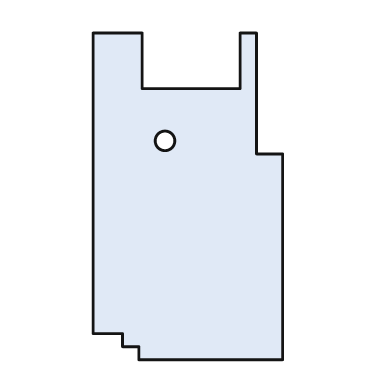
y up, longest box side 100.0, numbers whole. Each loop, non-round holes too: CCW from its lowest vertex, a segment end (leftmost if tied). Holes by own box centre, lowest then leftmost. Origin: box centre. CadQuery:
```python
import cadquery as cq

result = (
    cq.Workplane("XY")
    .moveTo(-15.0, -50.0)
    .lineTo(29.0, -50.0)
    .lineTo(29.0, 13.0)
    .lineTo(21.0, 13.0)
    .lineTo(21.0, 50.0)
    .lineTo(16.0, 50.0)
    .lineTo(16.0, 33.0)
    .lineTo(-14.0, 33.0)
    .lineTo(-14.0, 50.0)
    .lineTo(-29.0, 50.0)
    .lineTo(-29.0, -42.0)
    .lineTo(-20.0, -42.0)
    .lineTo(-20.0, -46.0)
    .lineTo(-15.0, -46.0)
    .close()
    .moveTo(-7.0, 17.0)
    .circle(3.0)
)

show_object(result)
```